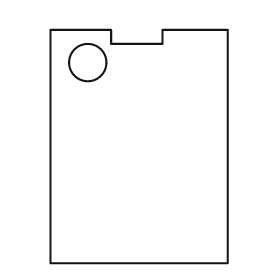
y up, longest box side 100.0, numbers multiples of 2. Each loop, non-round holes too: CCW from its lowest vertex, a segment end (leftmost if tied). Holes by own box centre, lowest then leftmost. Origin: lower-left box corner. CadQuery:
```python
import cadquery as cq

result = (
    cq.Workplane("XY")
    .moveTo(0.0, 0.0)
    .lineTo(76.0, 0.0)
    .lineTo(76.0, 100.0)
    .lineTo(48.0, 100.0)
    .lineTo(48.0, 94.0)
    .lineTo(26.0, 94.0)
    .lineTo(26.0, 100.0)
    .lineTo(0.0, 100.0)
    .close()
    .moveTo(16.0, 86.0)
    .circle(8.0)
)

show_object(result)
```